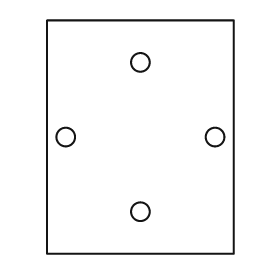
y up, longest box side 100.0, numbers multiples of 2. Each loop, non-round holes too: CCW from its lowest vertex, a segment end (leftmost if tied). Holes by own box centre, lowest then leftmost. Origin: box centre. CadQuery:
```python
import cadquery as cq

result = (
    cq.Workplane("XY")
    .moveTo(-40.0, -50.0)
    .lineTo(40.0, -50.0)
    .lineTo(40.0, 50.0)
    .lineTo(-40.0, 50.0)
    .close()
    .moveTo(0.0, -32.0)
    .circle(4.0)
    .moveTo(-32.0, 0.0)
    .circle(4.0)
    .moveTo(32.0, 0.0)
    .circle(4.0)
    .moveTo(0.0, 32.0)
    .circle(4.0)
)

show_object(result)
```